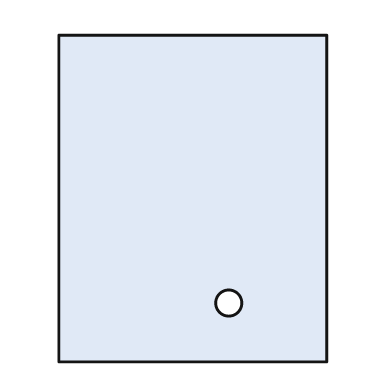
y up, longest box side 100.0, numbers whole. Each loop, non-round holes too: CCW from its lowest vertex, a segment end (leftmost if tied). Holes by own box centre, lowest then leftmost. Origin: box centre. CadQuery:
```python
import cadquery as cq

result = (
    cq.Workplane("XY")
    .moveTo(-41.0, -50.0)
    .lineTo(41.0, -50.0)
    .lineTo(41.0, 50.0)
    .lineTo(-41.0, 50.0)
    .close()
    .moveTo(11.0, -32.0)
    .circle(4.0)
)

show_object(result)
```